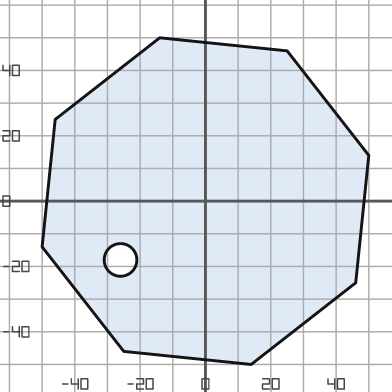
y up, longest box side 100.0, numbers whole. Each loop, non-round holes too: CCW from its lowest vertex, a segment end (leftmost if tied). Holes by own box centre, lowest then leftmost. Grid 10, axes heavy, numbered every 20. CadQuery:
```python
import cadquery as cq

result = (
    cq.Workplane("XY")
    .moveTo(14.0, -50.0)
    .lineTo(46.0, -25.0)
    .lineTo(50.0, 14.0)
    .lineTo(25.0, 46.0)
    .lineTo(-14.0, 50.0)
    .lineTo(-46.0, 25.0)
    .lineTo(-50.0, -14.0)
    .lineTo(-25.0, -46.0)
    .close()
    .moveTo(-26.0, -18.0)
    .circle(5.0)
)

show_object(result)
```